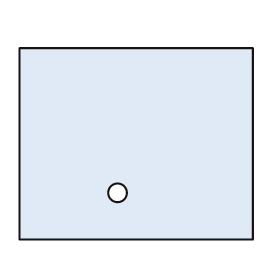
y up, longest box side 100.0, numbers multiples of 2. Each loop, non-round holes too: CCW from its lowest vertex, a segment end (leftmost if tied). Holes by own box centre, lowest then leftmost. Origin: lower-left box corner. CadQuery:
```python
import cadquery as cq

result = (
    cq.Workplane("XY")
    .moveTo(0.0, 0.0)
    .lineTo(100.0, 0.0)
    .lineTo(100.0, 82.0)
    .lineTo(0.0, 82.0)
    .close()
    .moveTo(42.0, 20.0)
    .circle(4.0)
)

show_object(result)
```